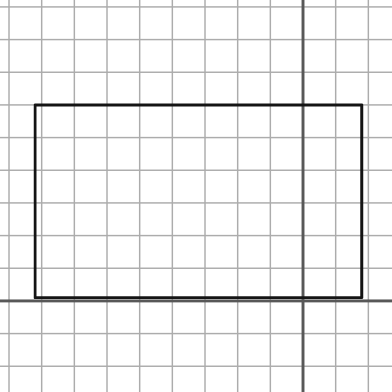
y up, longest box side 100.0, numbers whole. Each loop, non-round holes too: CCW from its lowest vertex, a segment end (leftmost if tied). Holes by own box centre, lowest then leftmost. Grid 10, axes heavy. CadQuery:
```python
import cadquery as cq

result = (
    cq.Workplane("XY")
    .moveTo(-82.0, 1.0)
    .lineTo(18.0, 1.0)
    .lineTo(18.0, 60.0)
    .lineTo(-82.0, 60.0)
    .close()
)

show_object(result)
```